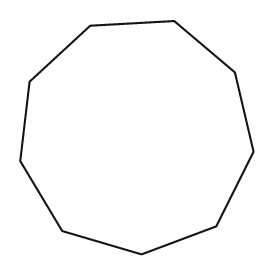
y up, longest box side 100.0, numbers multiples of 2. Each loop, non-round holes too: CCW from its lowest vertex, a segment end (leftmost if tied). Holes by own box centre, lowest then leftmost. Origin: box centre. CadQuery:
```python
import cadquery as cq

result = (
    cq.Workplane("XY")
    .moveTo(2.0, -50.0)
    .lineTo(34.0, -38.0)
    .lineTo(50.0, -6.0)
    .lineTo(42.0, 28.0)
    .lineTo(16.0, 50.0)
    .lineTo(-20.0, 48.0)
    .lineTo(-46.0, 24.0)
    .lineTo(-50.0, -10.0)
    .lineTo(-32.0, -40.0)
    .close()
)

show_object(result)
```